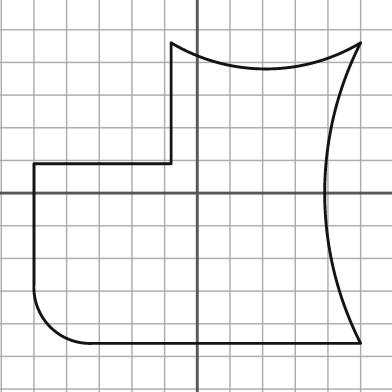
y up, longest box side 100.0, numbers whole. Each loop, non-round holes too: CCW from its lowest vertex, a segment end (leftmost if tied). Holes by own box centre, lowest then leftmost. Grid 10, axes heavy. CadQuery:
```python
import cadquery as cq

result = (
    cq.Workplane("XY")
    .moveTo(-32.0, -46.0)
    .lineTo(50.0, -46.0)
    .threePointArc((39.0, 0.0), (50.0, 46.0))
    .threePointArc((21.0, 38.0), (-8.0, 46.0))
    .lineTo(-8.0, 9.0)
    .lineTo(-50.0, 9.0)
    .lineTo(-50.0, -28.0)
    .threePointArc((-45.0, -41.0), (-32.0, -46.0))
    .close()
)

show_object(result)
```